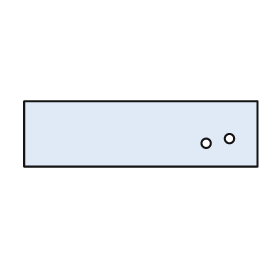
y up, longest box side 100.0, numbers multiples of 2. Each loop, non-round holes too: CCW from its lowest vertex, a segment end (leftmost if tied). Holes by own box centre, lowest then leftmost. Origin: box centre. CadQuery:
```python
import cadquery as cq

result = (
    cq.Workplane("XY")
    .moveTo(-50.0, -14.0)
    .lineTo(50.0, -14.0)
    .lineTo(50.0, 14.0)
    .lineTo(-50.0, 14.0)
    .close()
    .moveTo(28.0, -4.0)
    .circle(2.0)
    .moveTo(38.0, -2.0)
    .circle(2.0)
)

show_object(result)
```